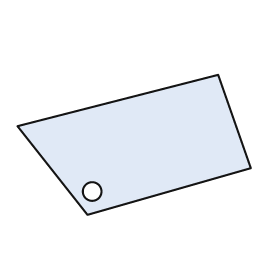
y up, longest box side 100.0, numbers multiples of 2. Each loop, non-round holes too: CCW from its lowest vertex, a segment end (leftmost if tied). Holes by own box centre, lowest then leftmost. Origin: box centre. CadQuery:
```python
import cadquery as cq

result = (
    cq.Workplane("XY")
    .moveTo(-20.0, -30.0)
    .lineTo(50.0, -10.0)
    .lineTo(36.0, 30.0)
    .lineTo(-50.0, 8.0)
    .close()
    .moveTo(-18.0, -20.0)
    .circle(4.0)
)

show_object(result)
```